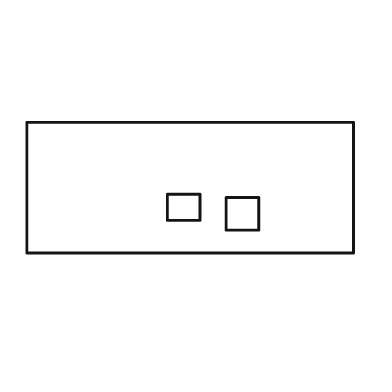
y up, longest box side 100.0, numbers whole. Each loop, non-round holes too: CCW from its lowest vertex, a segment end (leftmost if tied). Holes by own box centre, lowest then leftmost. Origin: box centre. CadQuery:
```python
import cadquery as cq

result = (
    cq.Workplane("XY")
    .moveTo(-50.0, -20.0)
    .lineTo(50.0, -20.0)
    .lineTo(50.0, 20.0)
    .lineTo(-50.0, 20.0)
    .close()
    .moveTo(11.0, -13.0)
    .lineTo(21.0, -13.0)
    .lineTo(21.0, -3.0)
    .lineTo(11.0, -3.0)
    .close()
    .moveTo(-7.0, -10.0)
    .lineTo(3.0, -10.0)
    .lineTo(3.0, -2.0)
    .lineTo(-7.0, -2.0)
    .close()
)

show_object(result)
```